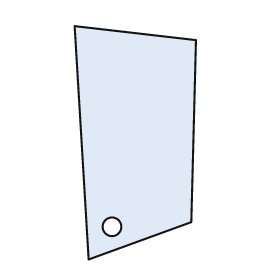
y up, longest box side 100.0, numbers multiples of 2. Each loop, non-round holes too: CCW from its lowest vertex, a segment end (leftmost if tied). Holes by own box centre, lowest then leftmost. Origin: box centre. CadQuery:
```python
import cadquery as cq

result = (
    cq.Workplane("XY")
    .moveTo(-20.0, -50.0)
    .lineTo(24.0, -34.0)
    .lineTo(26.0, 44.0)
    .lineTo(-26.0, 50.0)
    .close()
    .moveTo(-10.0, -36.0)
    .circle(4.0)
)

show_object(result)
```